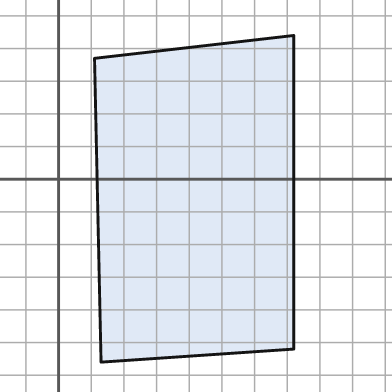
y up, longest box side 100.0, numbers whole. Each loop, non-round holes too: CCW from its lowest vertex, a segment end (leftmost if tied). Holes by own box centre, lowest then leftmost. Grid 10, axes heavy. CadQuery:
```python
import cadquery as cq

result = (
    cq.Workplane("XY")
    .moveTo(13.0, -56.0)
    .lineTo(72.0, -52.0)
    .lineTo(72.0, 44.0)
    .lineTo(11.0, 37.0)
    .close()
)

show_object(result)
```